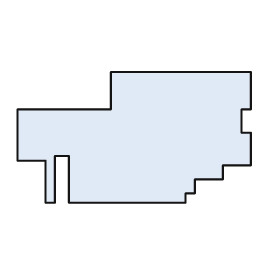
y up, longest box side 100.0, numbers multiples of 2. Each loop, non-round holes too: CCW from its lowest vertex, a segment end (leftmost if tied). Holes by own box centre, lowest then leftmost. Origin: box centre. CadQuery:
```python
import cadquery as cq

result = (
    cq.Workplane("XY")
    .moveTo(-38.0, -28.0)
    .lineTo(-34.0, -28.0)
    .lineTo(-34.0, -8.0)
    .lineTo(-28.0, -8.0)
    .lineTo(-28.0, -28.0)
    .lineTo(22.0, -28.0)
    .lineTo(22.0, -24.0)
    .lineTo(26.0, -24.0)
    .lineTo(26.0, -18.0)
    .lineTo(38.0, -18.0)
    .lineTo(38.0, -12.0)
    .lineTo(50.0, -12.0)
    .lineTo(50.0, 2.0)
    .lineTo(46.0, 2.0)
    .lineTo(46.0, 12.0)
    .lineTo(50.0, 12.0)
    .lineTo(50.0, 28.0)
    .lineTo(-10.0, 28.0)
    .lineTo(-10.0, 12.0)
    .lineTo(-50.0, 12.0)
    .lineTo(-50.0, -10.0)
    .lineTo(-38.0, -10.0)
    .close()
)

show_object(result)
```